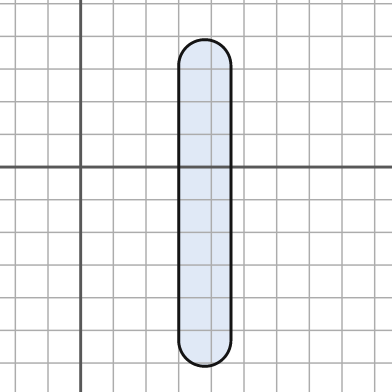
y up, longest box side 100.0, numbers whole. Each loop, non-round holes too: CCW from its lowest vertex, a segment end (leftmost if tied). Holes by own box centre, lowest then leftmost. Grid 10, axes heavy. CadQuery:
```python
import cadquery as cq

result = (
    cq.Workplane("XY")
    .moveTo(30.0, -53.0)
    .threePointArc((38.0, -61.0), (46.0, -53.0))
    .lineTo(46.0, 31.0)
    .threePointArc((38.0, 39.0), (30.0, 31.0))
    .close()
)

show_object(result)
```